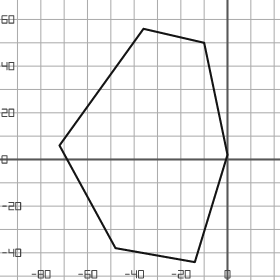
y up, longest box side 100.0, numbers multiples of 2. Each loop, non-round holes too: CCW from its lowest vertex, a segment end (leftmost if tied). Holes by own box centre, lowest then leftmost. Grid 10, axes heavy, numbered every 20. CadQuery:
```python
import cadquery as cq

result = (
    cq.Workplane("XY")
    .moveTo(-14.0, -44.0)
    .lineTo(0.0, 2.0)
    .lineTo(-10.0, 50.0)
    .lineTo(-36.0, 56.0)
    .lineTo(-72.0, 6.0)
    .lineTo(-48.0, -38.0)
    .close()
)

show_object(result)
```